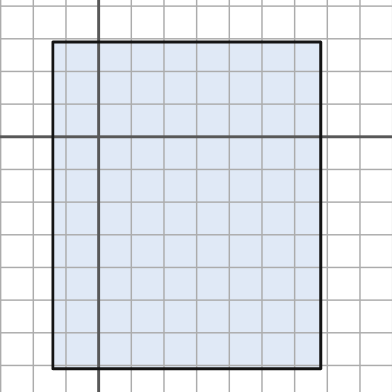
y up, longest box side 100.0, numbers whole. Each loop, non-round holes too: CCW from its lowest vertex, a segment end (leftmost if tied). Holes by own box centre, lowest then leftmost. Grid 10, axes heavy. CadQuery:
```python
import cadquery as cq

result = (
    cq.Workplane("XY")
    .moveTo(-14.0, -71.0)
    .lineTo(68.0, -71.0)
    .lineTo(68.0, 29.0)
    .lineTo(-14.0, 29.0)
    .close()
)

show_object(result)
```